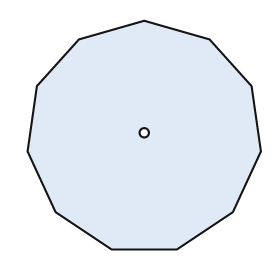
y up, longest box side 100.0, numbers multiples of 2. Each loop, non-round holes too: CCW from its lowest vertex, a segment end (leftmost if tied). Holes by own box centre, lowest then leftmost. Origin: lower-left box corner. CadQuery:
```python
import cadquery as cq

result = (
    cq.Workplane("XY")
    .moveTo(36.0, 0.0)
    .lineTo(64.0, 0.0)
    .lineTo(88.0, 16.0)
    .lineTo(100.0, 42.0)
    .lineTo(96.0, 70.0)
    .lineTo(78.0, 90.0)
    .lineTo(50.0, 98.0)
    .lineTo(22.0, 90.0)
    .lineTo(4.0, 70.0)
    .lineTo(0.0, 42.0)
    .lineTo(12.0, 16.0)
    .close()
    .moveTo(50.0, 50.0)
    .circle(2.0)
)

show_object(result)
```